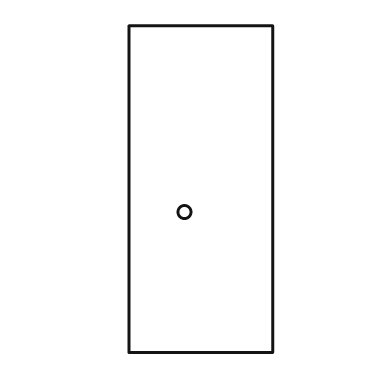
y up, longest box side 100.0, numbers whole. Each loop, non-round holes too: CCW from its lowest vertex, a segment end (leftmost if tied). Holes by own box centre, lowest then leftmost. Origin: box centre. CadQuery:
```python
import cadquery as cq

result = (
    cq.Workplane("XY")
    .moveTo(-22.0, -50.0)
    .lineTo(22.0, -50.0)
    .lineTo(22.0, 50.0)
    .lineTo(-22.0, 50.0)
    .close()
    .moveTo(-5.0, -7.0)
    .circle(2.0)
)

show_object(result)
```